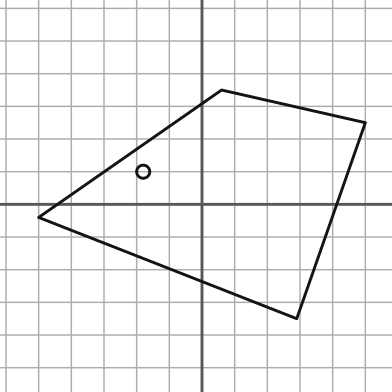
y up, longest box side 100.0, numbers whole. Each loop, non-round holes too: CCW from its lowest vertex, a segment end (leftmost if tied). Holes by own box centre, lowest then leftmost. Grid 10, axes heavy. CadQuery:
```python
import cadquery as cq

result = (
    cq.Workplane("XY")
    .moveTo(29.0, -35.0)
    .lineTo(50.0, 25.0)
    .lineTo(6.0, 35.0)
    .lineTo(-50.0, -4.0)
    .close()
    .moveTo(-18.0, 10.0)
    .circle(2.0)
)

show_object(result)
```